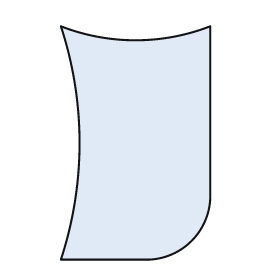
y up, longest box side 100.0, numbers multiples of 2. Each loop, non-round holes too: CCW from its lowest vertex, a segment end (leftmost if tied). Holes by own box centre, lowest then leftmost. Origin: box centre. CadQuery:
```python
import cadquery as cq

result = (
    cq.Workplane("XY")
    .moveTo(-32.0, -50.0)
    .lineTo(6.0, -50.0)
    .threePointArc((24.0, -42.0), (32.0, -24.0))
    .lineTo(32.0, 50.0)
    .threePointArc((0.0, 44.0), (-32.0, 50.0))
    .threePointArc((-24.0, 0.0), (-32.0, -50.0))
    .close()
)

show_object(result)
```